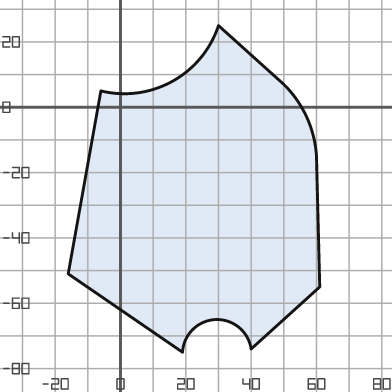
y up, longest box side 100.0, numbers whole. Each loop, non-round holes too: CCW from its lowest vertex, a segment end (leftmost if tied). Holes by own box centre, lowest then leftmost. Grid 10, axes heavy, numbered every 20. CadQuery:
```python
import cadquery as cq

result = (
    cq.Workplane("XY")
    .moveTo(19.0, -75.0)
    .threePointArc((29.0, -65.0), (40.0, -74.0))
    .lineTo(61.0, -55.0)
    .lineTo(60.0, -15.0)
    .threePointArc((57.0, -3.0), (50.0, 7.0))
    .lineTo(30.0, 25.0)
    .threePointArc((16.0, 8.0), (-6.0, 5.0))
    .lineTo(-16.0, -51.0)
    .close()
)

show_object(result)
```